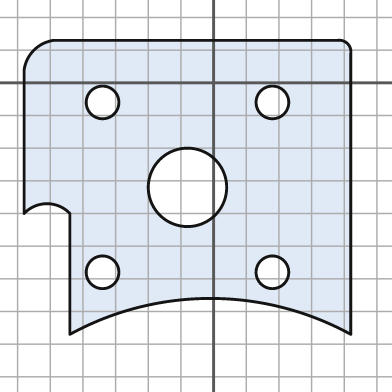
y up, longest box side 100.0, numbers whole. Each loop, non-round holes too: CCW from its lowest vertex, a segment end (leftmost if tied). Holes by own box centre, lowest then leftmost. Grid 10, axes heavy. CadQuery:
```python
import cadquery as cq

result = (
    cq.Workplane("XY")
    .moveTo(-44.0, -77.0)
    .threePointArc((-1.0, -66.0), (42.0, -77.0))
    .lineTo(42.0, 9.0)
    .threePointArc((41.0, 12.0), (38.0, 13.0))
    .lineTo(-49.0, 13.0)
    .threePointArc((-55.0, 10.0), (-58.0, 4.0))
    .lineTo(-58.0, -40.0)
    .threePointArc((-51.0, -37.0), (-44.0, -40.0))
    .close()
    .moveTo(-34.0, -58.0)
    .circle(5.0)
    .moveTo(18.0, -58.0)
    .circle(5.0)
    .moveTo(-8.0, -32.0)
    .circle(12.0)
    .moveTo(-34.0, -6.0)
    .circle(5.0)
    .moveTo(18.0, -6.0)
    .circle(5.0)
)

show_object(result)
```